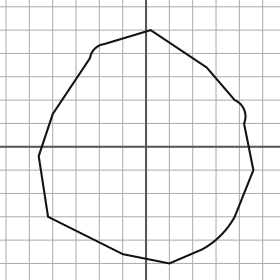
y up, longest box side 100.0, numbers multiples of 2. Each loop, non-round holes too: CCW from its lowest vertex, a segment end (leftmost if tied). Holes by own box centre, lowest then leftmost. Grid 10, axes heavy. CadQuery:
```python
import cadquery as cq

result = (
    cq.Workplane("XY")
    .moveTo(10.0, -50.0)
    .lineTo(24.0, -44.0)
    .threePointArc((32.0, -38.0), (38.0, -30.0))
    .lineTo(46.0, -10.0)
    .lineTo(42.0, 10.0)
    .threePointArc((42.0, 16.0), (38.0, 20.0))
    .lineTo(26.0, 34.0)
    .lineTo(2.0, 50.0)
    .lineTo(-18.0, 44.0)
    .threePointArc((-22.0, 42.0), (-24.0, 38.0))
    .lineTo(-40.0, 14.0)
    .lineTo(-46.0, -4.0)
    .lineTo(-42.0, -30.0)
    .lineTo(-10.0, -46.0)
    .close()
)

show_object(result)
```